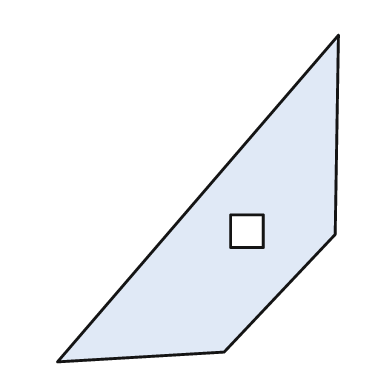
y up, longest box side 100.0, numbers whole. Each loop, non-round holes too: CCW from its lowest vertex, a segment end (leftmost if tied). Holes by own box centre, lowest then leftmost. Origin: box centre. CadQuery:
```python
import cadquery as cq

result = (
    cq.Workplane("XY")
    .moveTo(-43.0, -50.0)
    .lineTo(8.0, -47.0)
    .lineTo(42.0, -11.0)
    .lineTo(43.0, 50.0)
    .close()
    .moveTo(10.0, -15.0)
    .lineTo(20.0, -15.0)
    .lineTo(20.0, -5.0)
    .lineTo(10.0, -5.0)
    .close()
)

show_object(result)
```